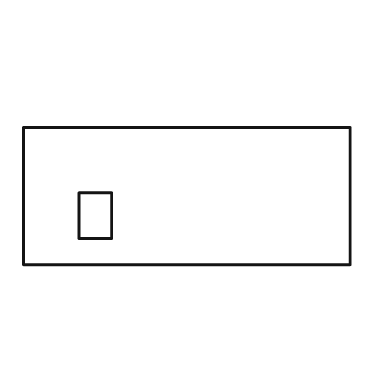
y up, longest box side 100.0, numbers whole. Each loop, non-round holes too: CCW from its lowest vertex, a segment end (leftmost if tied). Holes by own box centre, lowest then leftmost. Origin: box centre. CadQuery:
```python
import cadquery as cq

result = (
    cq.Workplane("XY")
    .moveTo(-50.0, -21.0)
    .lineTo(50.0, -21.0)
    .lineTo(50.0, 21.0)
    .lineTo(-50.0, 21.0)
    .close()
    .moveTo(-33.0, -13.0)
    .lineTo(-23.0, -13.0)
    .lineTo(-23.0, 1.0)
    .lineTo(-33.0, 1.0)
    .close()
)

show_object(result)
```